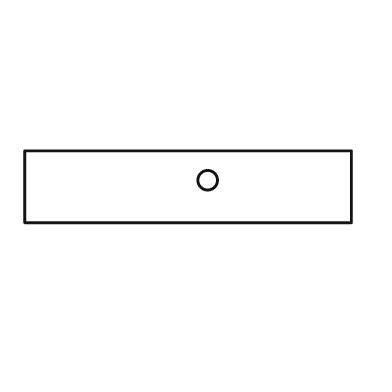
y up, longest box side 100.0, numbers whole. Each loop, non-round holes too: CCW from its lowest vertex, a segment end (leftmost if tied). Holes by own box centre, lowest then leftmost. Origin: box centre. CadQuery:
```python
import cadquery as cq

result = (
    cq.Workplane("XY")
    .moveTo(-50.0, -11.0)
    .lineTo(50.0, -11.0)
    .lineTo(50.0, 11.0)
    .lineTo(-50.0, 11.0)
    .close()
    .moveTo(6.0, 2.0)
    .circle(3.0)
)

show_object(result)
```